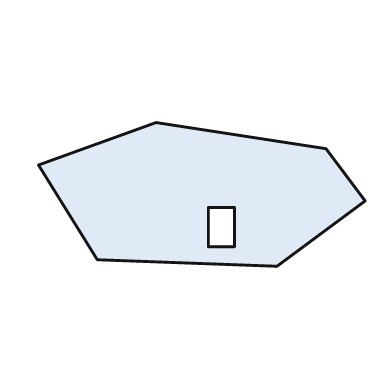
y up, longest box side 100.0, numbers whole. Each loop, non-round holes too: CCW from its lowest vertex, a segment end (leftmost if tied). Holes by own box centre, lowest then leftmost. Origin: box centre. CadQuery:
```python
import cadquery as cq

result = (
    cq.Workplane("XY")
    .moveTo(23.0, -22.0)
    .lineTo(50.0, -2.0)
    .lineTo(38.0, 14.0)
    .lineTo(-14.0, 22.0)
    .lineTo(-50.0, 9.0)
    .lineTo(-32.0, -20.0)
    .close()
    .moveTo(2.0, -16.0)
    .lineTo(10.0, -16.0)
    .lineTo(10.0, -4.0)
    .lineTo(2.0, -4.0)
    .close()
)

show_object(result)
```